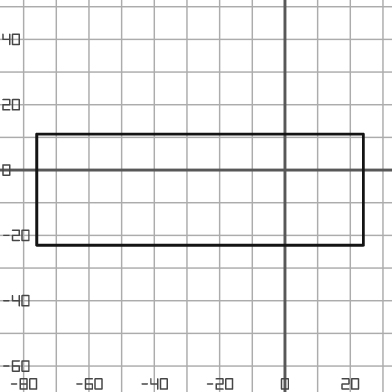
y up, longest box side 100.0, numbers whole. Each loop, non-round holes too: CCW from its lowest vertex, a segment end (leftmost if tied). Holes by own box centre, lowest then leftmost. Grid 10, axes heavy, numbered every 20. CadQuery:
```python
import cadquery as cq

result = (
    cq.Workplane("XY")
    .moveTo(-76.0, -23.0)
    .lineTo(24.0, -23.0)
    .lineTo(24.0, 11.0)
    .lineTo(-76.0, 11.0)
    .close()
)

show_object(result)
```